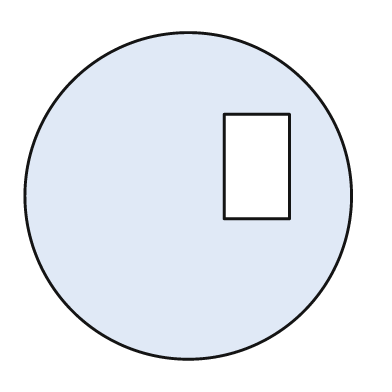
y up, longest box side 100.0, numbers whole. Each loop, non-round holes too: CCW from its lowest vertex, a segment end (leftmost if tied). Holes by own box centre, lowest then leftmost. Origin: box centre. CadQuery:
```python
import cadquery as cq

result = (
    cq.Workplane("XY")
    .moveTo(0.0, 0.0)
    .circle(50.0)
    .moveTo(11.0, -7.0)
    .lineTo(31.0, -7.0)
    .lineTo(31.0, 25.0)
    .lineTo(11.0, 25.0)
    .close()
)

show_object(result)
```